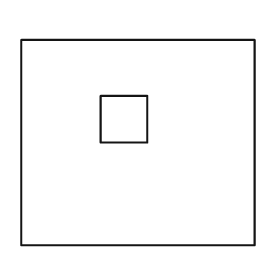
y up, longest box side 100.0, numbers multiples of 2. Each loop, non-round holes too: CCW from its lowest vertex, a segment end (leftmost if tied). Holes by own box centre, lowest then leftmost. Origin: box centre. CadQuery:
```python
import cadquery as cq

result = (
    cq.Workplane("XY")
    .moveTo(-50.0, -44.0)
    .lineTo(50.0, -44.0)
    .lineTo(50.0, 44.0)
    .lineTo(-50.0, 44.0)
    .close()
    .moveTo(-16.0, 0.0)
    .lineTo(4.0, 0.0)
    .lineTo(4.0, 20.0)
    .lineTo(-16.0, 20.0)
    .close()
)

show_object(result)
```